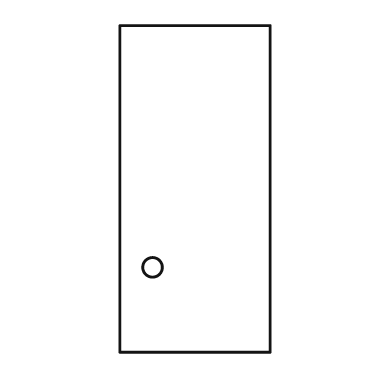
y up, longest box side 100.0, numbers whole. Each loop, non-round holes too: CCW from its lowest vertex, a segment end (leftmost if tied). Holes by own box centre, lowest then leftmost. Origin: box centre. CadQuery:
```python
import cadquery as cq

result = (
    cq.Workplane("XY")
    .moveTo(-23.0, -50.0)
    .lineTo(23.0, -50.0)
    .lineTo(23.0, 50.0)
    .lineTo(-23.0, 50.0)
    .close()
    .moveTo(-13.0, -24.0)
    .circle(3.0)
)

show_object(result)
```